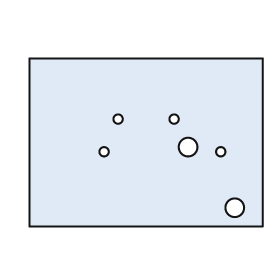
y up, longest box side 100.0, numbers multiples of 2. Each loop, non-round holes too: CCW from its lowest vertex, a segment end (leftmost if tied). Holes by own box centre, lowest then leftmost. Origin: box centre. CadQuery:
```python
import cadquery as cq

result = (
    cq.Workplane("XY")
    .moveTo(-50.0, -36.0)
    .lineTo(50.0, -36.0)
    .lineTo(50.0, 36.0)
    .lineTo(-50.0, 36.0)
    .close()
    .moveTo(38.0, -28.0)
    .circle(4.0)
    .moveTo(-18.0, -4.0)
    .circle(2.0)
    .moveTo(32.0, -4.0)
    .circle(2.0)
    .moveTo(18.0, -2.0)
    .circle(4.0)
    .moveTo(-12.0, 10.0)
    .circle(2.0)
    .moveTo(12.0, 10.0)
    .circle(2.0)
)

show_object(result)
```